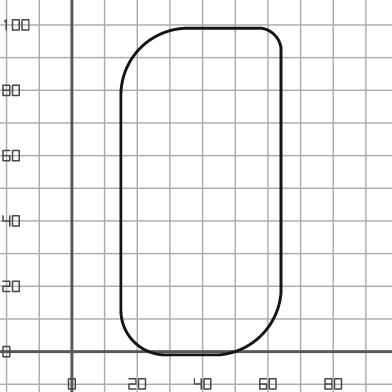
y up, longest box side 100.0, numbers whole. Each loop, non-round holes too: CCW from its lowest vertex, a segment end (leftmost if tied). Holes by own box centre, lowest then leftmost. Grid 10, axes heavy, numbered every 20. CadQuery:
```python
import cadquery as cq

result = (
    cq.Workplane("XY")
    .moveTo(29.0, -1.0)
    .lineTo(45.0, -1.0)
    .threePointArc((58.0, 5.0), (64.0, 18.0))
    .lineTo(64.0, 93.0)
    .threePointArc((62.0, 97.0), (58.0, 99.0))
    .lineTo(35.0, 99.0)
    .threePointArc((21.0, 93.0), (15.0, 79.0))
    .lineTo(15.0, 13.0)
    .threePointArc((19.0, 3.0), (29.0, -1.0))
    .close()
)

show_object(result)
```